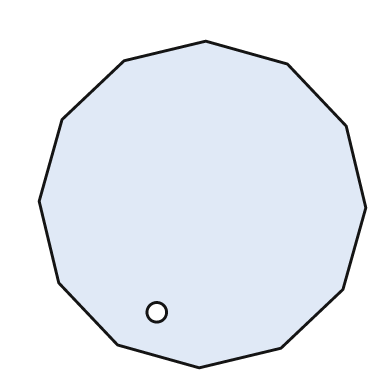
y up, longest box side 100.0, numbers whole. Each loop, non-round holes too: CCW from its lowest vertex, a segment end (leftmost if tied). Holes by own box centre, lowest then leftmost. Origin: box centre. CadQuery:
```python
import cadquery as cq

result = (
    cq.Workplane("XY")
    .moveTo(-1.0, -50.0)
    .lineTo(24.0, -44.0)
    .lineTo(43.0, -26.0)
    .lineTo(50.0, -1.0)
    .lineTo(44.0, 24.0)
    .lineTo(26.0, 43.0)
    .lineTo(1.0, 50.0)
    .lineTo(-24.0, 44.0)
    .lineTo(-43.0, 26.0)
    .lineTo(-50.0, 1.0)
    .lineTo(-44.0, -24.0)
    .lineTo(-26.0, -43.0)
    .close()
    .moveTo(-14.0, -33.0)
    .circle(3.0)
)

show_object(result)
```